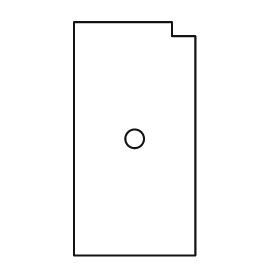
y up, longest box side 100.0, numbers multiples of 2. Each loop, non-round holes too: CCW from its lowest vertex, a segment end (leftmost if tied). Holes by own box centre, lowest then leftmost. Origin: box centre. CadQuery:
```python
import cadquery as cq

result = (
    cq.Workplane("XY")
    .moveTo(-26.0, -50.0)
    .lineTo(26.0, -50.0)
    .lineTo(26.0, 44.0)
    .lineTo(16.0, 44.0)
    .lineTo(16.0, 50.0)
    .lineTo(-26.0, 50.0)
    .close()
    .moveTo(0.0, 0.0)
    .circle(4.0)
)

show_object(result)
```